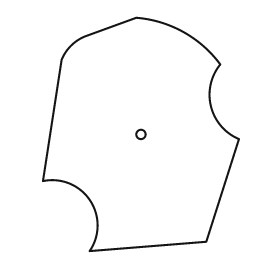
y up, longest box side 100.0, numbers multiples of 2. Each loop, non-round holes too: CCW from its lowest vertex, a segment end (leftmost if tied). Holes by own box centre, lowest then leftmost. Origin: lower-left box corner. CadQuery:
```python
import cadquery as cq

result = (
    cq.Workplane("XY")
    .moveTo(20.0, 0.0)
    .lineTo(70.0, 4.0)
    .lineTo(84.0, 48.0)
    .threePointArc((72.0, 62.0), (76.0, 80.0))
    .threePointArc((60.0, 94.0), (40.0, 100.0))
    .lineTo(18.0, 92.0)
    .threePointArc((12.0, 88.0), (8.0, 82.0))
    .lineTo(0.0, 30.0)
    .threePointArc((20.0, 22.0), (20.0, 0.0))
    .close()
    .moveTo(42.0, 50.0)
    .circle(2.0)
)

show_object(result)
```